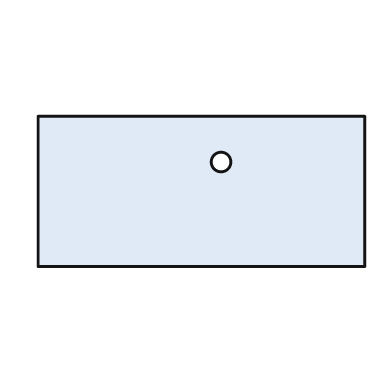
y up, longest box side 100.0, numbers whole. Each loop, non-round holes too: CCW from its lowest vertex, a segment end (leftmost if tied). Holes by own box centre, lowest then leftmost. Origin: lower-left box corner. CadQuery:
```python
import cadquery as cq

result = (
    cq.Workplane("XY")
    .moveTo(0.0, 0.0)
    .lineTo(100.0, 0.0)
    .lineTo(100.0, 46.0)
    .lineTo(0.0, 46.0)
    .close()
    .moveTo(56.0, 32.0)
    .circle(3.0)
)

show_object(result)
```